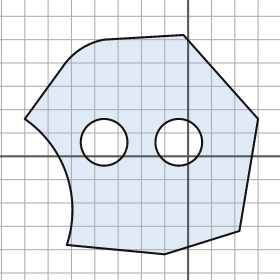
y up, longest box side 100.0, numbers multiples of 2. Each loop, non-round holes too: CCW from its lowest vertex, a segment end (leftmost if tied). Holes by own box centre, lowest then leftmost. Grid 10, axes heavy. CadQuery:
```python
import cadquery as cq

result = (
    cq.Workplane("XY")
    .moveTo(-10.0, -42.0)
    .lineTo(22.0, -32.0)
    .lineTo(30.0, 16.0)
    .lineTo(-2.0, 52.0)
    .lineTo(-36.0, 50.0)
    .threePointArc((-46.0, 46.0), (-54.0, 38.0))
    .lineTo(-70.0, 16.0)
    .threePointArc((-52.0, -8.0), (-52.0, -38.0))
    .close()
    .moveTo(-36.0, 6.0)
    .circle(10.0)
    .moveTo(-4.0, 6.0)
    .circle(10.0)
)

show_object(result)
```